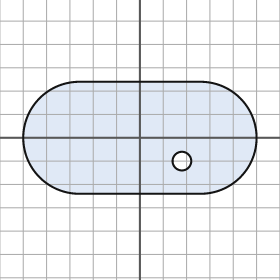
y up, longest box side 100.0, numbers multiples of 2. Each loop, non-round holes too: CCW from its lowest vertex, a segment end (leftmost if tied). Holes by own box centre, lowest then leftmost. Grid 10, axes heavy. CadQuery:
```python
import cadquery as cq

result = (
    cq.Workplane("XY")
    .moveTo(-26.0, -24.0)
    .lineTo(26.0, -24.0)
    .threePointArc((50.0, 0.0), (26.0, 24.0))
    .lineTo(-26.0, 24.0)
    .threePointArc((-50.0, 0.0), (-26.0, -24.0))
    .close()
    .moveTo(18.0, -10.0)
    .circle(4.0)
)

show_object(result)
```